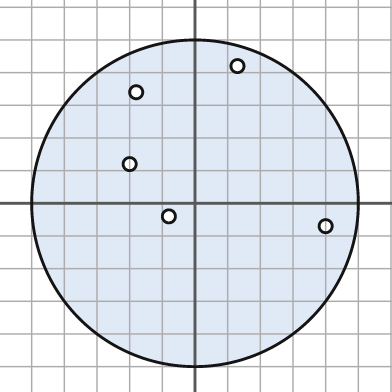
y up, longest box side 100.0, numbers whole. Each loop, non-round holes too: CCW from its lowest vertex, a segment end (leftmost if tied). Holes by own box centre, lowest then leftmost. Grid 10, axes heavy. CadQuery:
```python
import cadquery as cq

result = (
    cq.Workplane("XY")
    .moveTo(0.0, 0.0)
    .circle(50.0)
    .moveTo(40.0, -7.0)
    .circle(2.0)
    .moveTo(-8.0, -4.0)
    .circle(2.0)
    .moveTo(-20.0, 12.0)
    .circle(2.0)
    .moveTo(-18.0, 34.0)
    .circle(2.0)
    .moveTo(13.0, 42.0)
    .circle(2.0)
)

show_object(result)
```